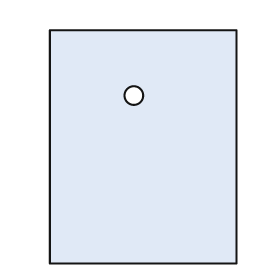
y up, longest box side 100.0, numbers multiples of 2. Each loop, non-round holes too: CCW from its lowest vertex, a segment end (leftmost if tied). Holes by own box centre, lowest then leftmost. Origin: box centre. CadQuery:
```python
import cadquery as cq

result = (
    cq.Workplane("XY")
    .moveTo(-40.0, -50.0)
    .lineTo(40.0, -50.0)
    .lineTo(40.0, 50.0)
    .lineTo(-40.0, 50.0)
    .close()
    .moveTo(-4.0, 22.0)
    .circle(4.0)
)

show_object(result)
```